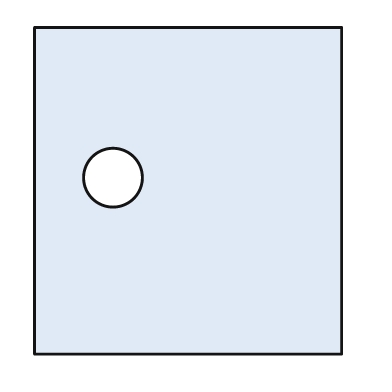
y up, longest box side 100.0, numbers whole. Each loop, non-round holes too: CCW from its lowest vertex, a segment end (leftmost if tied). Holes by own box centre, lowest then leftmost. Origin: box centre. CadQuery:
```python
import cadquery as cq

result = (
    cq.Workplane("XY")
    .moveTo(-47.0, -50.0)
    .lineTo(47.0, -50.0)
    .lineTo(47.0, 50.0)
    .lineTo(-47.0, 50.0)
    .close()
    .moveTo(-23.0, 4.0)
    .circle(9.0)
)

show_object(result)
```